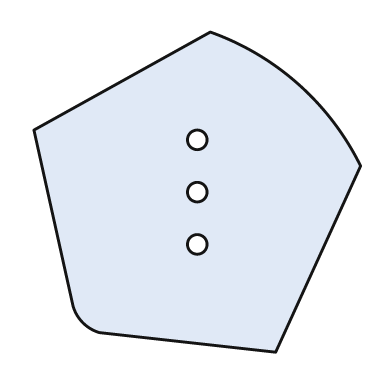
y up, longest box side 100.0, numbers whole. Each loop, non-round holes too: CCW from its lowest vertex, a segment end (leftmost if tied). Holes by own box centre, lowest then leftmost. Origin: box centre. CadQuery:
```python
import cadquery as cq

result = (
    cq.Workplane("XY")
    .moveTo(24.0, -49.0)
    .lineTo(50.0, 8.0)
    .threePointArc((31.0, 33.0), (4.0, 49.0))
    .lineTo(-50.0, 19.0)
    .lineTo(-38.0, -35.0)
    .threePointArc((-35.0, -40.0), (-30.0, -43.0))
    .close()
    .moveTo(0.0, -16.0)
    .circle(3.0)
    .moveTo(0.0, 0.0)
    .circle(3.0)
    .moveTo(0.0, 16.0)
    .circle(3.0)
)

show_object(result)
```